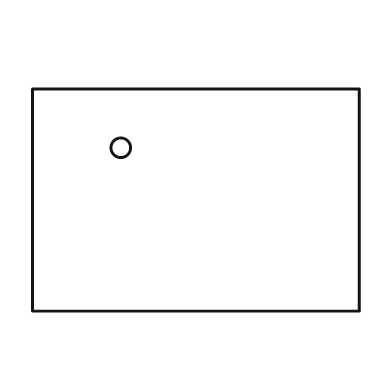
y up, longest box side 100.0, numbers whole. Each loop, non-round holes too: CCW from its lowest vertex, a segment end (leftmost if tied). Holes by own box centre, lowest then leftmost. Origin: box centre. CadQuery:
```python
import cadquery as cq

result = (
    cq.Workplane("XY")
    .moveTo(-50.0, -34.0)
    .lineTo(50.0, -34.0)
    .lineTo(50.0, 34.0)
    .lineTo(-50.0, 34.0)
    .close()
    .moveTo(-23.0, 16.0)
    .circle(3.0)
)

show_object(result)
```